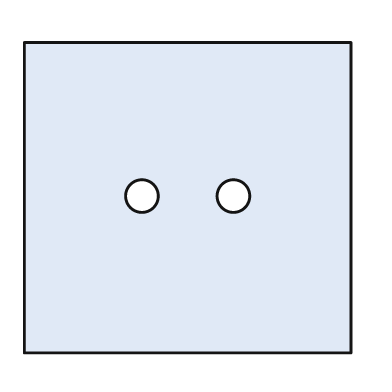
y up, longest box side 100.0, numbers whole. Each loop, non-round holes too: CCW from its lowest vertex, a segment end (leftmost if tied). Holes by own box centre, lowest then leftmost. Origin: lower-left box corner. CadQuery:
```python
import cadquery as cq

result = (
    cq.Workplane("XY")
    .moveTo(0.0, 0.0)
    .lineTo(100.0, 0.0)
    .lineTo(100.0, 95.0)
    .lineTo(0.0, 95.0)
    .close()
    .moveTo(36.0, 48.0)
    .circle(5.0)
    .moveTo(64.0, 48.0)
    .circle(5.0)
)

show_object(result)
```